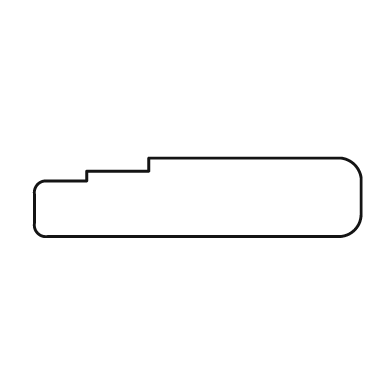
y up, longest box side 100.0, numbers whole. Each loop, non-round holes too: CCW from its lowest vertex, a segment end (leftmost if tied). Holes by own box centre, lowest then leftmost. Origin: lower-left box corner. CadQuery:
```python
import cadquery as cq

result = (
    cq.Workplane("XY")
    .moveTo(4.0, 0.0)
    .lineTo(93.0, 0.0)
    .threePointArc((98.0, 2.0), (100.0, 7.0))
    .lineTo(100.0, 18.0)
    .threePointArc((98.0, 22.0), (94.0, 24.0))
    .lineTo(35.0, 24.0)
    .lineTo(35.0, 20.0)
    .lineTo(16.0, 20.0)
    .lineTo(16.0, 17.0)
    .lineTo(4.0, 17.0)
    .threePointArc((1.0, 16.0), (0.0, 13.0))
    .lineTo(0.0, 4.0)
    .threePointArc((1.0, 1.0), (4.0, 0.0))
    .close()
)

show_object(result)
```